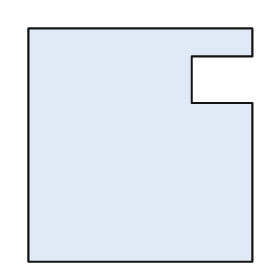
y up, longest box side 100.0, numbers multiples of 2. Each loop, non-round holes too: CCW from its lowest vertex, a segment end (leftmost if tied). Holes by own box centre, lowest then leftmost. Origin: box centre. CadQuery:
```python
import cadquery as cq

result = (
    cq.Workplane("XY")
    .moveTo(-48.0, -50.0)
    .lineTo(48.0, -50.0)
    .lineTo(48.0, 18.0)
    .lineTo(22.0, 18.0)
    .lineTo(22.0, 38.0)
    .lineTo(48.0, 38.0)
    .lineTo(48.0, 50.0)
    .lineTo(-48.0, 50.0)
    .close()
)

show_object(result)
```